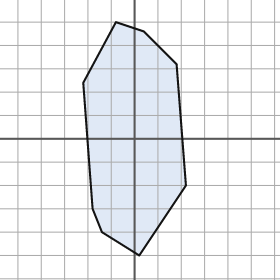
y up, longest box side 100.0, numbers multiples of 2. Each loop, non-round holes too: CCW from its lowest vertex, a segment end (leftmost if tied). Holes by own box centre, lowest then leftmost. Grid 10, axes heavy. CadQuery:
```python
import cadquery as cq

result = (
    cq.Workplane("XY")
    .moveTo(2.0, -50.0)
    .lineTo(22.0, -20.0)
    .lineTo(18.0, 32.0)
    .lineTo(4.0, 46.0)
    .lineTo(-8.0, 50.0)
    .lineTo(-22.0, 24.0)
    .lineTo(-18.0, -30.0)
    .lineTo(-14.0, -40.0)
    .close()
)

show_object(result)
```